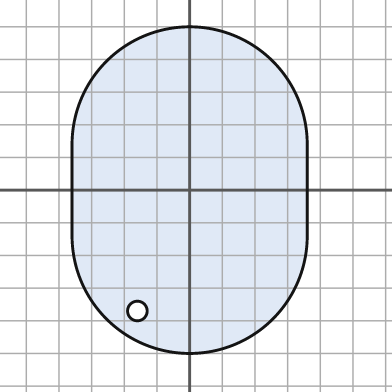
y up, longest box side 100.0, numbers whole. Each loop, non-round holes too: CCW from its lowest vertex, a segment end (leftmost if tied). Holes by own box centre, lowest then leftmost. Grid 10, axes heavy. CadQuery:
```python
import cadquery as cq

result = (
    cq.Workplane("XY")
    .moveTo(-36.0, -14.0)
    .threePointArc((0.0, -50.0), (36.0, -14.0))
    .lineTo(36.0, 14.0)
    .threePointArc((0.0, 50.0), (-36.0, 14.0))
    .close()
    .moveTo(-16.0, -37.0)
    .circle(3.0)
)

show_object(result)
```